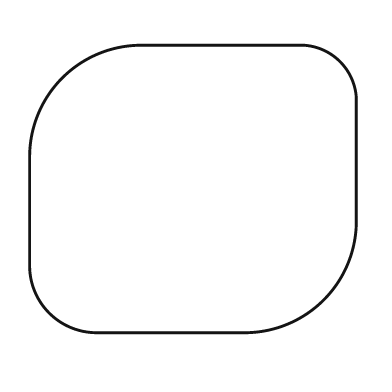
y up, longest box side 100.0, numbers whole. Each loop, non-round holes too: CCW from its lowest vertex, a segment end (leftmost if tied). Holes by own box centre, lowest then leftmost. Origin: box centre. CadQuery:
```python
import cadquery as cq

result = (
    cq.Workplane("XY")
    .moveTo(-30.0, -44.0)
    .lineTo(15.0, -44.0)
    .threePointArc((40.0, -34.0), (50.0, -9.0))
    .lineTo(50.0, 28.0)
    .threePointArc((45.0, 39.0), (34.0, 44.0))
    .lineTo(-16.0, 44.0)
    .threePointArc((-40.0, 34.0), (-50.0, 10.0))
    .lineTo(-50.0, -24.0)
    .threePointArc((-44.0, -38.0), (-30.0, -44.0))
    .close()
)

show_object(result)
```